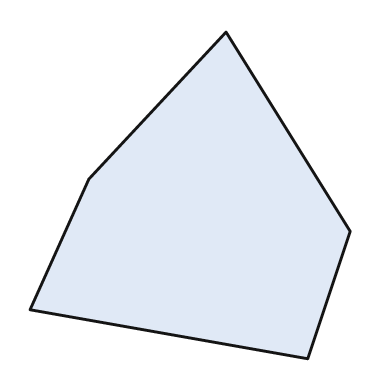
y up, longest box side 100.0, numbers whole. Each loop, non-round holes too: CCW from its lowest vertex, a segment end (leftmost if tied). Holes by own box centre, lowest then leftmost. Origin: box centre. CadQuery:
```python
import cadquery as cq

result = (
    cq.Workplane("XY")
    .moveTo(36.0, -50.0)
    .lineTo(49.0, -11.0)
    .lineTo(11.0, 50.0)
    .lineTo(-31.0, 5.0)
    .lineTo(-49.0, -35.0)
    .close()
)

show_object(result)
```